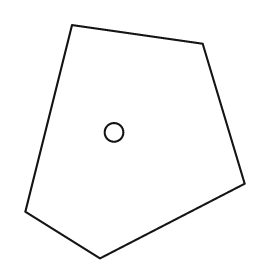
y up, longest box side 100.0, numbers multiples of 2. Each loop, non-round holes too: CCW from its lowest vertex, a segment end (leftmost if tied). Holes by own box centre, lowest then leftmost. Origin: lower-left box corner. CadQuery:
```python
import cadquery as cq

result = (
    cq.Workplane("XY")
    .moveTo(32.0, 0.0)
    .lineTo(94.0, 32.0)
    .lineTo(76.0, 92.0)
    .lineTo(20.0, 100.0)
    .lineTo(0.0, 20.0)
    .close()
    .moveTo(38.0, 54.0)
    .circle(4.0)
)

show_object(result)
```